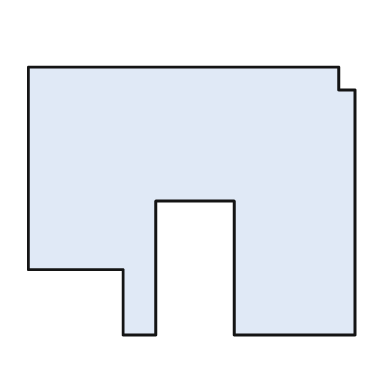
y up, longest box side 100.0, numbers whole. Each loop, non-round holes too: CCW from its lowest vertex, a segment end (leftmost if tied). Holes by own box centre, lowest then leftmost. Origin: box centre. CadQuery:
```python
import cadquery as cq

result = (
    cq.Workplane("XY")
    .moveTo(-21.0, -41.0)
    .lineTo(-11.0, -41.0)
    .lineTo(-11.0, 0.0)
    .lineTo(13.0, 0.0)
    .lineTo(13.0, -41.0)
    .lineTo(50.0, -41.0)
    .lineTo(50.0, 34.0)
    .lineTo(45.0, 34.0)
    .lineTo(45.0, 41.0)
    .lineTo(-50.0, 41.0)
    .lineTo(-50.0, -21.0)
    .lineTo(-21.0, -21.0)
    .close()
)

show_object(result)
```